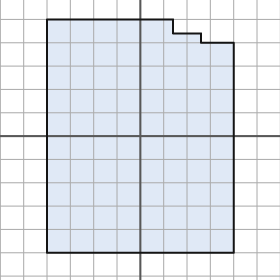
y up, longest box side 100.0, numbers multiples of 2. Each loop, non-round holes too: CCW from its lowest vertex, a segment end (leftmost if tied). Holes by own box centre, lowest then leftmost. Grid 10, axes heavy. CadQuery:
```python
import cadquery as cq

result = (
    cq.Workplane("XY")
    .moveTo(-40.0, -50.0)
    .lineTo(40.0, -50.0)
    .lineTo(40.0, 40.0)
    .lineTo(26.0, 40.0)
    .lineTo(26.0, 44.0)
    .lineTo(14.0, 44.0)
    .lineTo(14.0, 50.0)
    .lineTo(-40.0, 50.0)
    .close()
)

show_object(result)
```